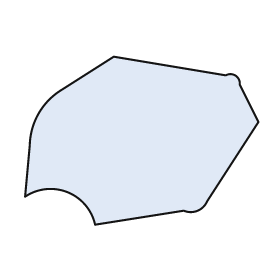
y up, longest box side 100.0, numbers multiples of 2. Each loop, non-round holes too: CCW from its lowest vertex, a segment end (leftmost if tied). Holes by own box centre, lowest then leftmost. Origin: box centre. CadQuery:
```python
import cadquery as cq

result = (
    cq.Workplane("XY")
    .moveTo(-20.0, -36.0)
    .lineTo(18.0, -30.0)
    .threePointArc((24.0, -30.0), (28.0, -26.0))
    .lineTo(50.0, 8.0)
    .lineTo(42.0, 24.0)
    .threePointArc((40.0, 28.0), (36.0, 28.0))
    .lineTo(-12.0, 36.0)
    .lineTo(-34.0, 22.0)
    .threePointArc((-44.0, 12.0), (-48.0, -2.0))
    .lineTo(-50.0, -24.0)
    .threePointArc((-32.0, -22.0), (-20.0, -36.0))
    .close()
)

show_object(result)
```